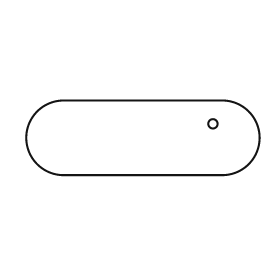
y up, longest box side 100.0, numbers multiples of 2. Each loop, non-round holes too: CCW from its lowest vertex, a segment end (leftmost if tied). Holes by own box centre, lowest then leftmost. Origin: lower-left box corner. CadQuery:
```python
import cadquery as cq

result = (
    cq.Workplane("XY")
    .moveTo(16.0, 0.0)
    .lineTo(84.0, 0.0)
    .threePointArc((100.0, 16.0), (84.0, 32.0))
    .lineTo(16.0, 32.0)
    .threePointArc((0.0, 16.0), (16.0, 0.0))
    .close()
    .moveTo(80.0, 22.0)
    .circle(2.0)
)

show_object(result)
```